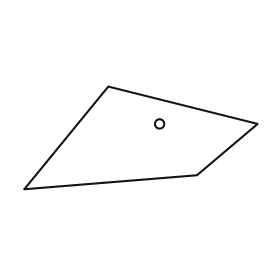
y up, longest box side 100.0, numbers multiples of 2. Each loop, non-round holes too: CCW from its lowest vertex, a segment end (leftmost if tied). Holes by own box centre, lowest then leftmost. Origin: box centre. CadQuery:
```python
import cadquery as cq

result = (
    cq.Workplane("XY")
    .moveTo(-50.0, -22.0)
    .lineTo(24.0, -16.0)
    .lineTo(50.0, 6.0)
    .lineTo(-14.0, 22.0)
    .close()
    .moveTo(8.0, 6.0)
    .circle(2.0)
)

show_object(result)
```